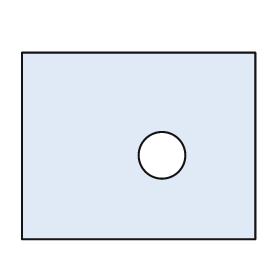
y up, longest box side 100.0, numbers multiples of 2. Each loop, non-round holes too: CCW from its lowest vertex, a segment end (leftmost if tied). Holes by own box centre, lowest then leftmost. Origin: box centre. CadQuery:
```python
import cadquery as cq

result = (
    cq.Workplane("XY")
    .moveTo(-50.0, -40.0)
    .lineTo(50.0, -40.0)
    .lineTo(50.0, 40.0)
    .lineTo(-50.0, 40.0)
    .close()
    .moveTo(10.0, -4.0)
    .circle(10.0)
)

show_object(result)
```